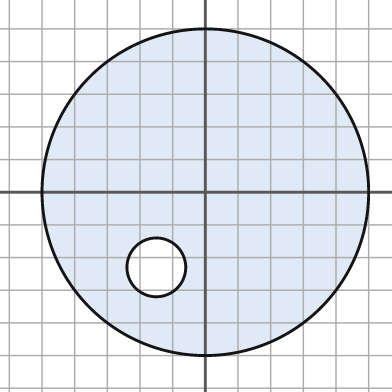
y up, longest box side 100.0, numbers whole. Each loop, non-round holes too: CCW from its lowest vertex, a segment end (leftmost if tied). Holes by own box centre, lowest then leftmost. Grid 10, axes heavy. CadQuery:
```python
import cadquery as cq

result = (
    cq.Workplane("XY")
    .moveTo(0.0, 0.0)
    .circle(50.0)
    .moveTo(-15.0, -23.0)
    .circle(9.0)
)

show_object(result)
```